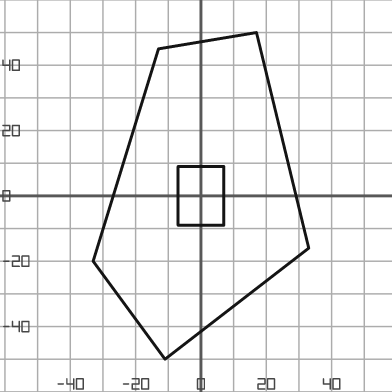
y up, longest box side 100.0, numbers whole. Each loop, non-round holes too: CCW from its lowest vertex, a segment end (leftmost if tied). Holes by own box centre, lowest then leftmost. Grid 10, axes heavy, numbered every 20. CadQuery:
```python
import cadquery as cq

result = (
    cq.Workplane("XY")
    .moveTo(-11.0, -50.0)
    .lineTo(33.0, -16.0)
    .lineTo(17.0, 50.0)
    .lineTo(-13.0, 45.0)
    .lineTo(-33.0, -20.0)
    .close()
    .moveTo(-7.0, -9.0)
    .lineTo(7.0, -9.0)
    .lineTo(7.0, 9.0)
    .lineTo(-7.0, 9.0)
    .close()
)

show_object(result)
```